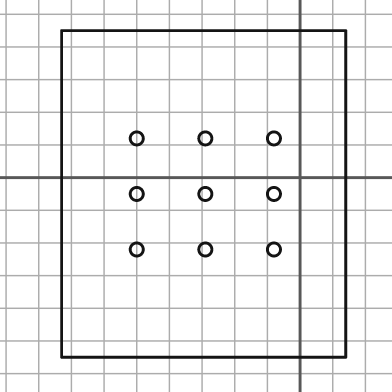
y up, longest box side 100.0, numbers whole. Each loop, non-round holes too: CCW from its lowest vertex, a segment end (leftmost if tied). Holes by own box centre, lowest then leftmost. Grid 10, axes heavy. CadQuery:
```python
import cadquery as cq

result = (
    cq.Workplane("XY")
    .moveTo(-73.0, -55.0)
    .lineTo(14.0, -55.0)
    .lineTo(14.0, 45.0)
    .lineTo(-73.0, 45.0)
    .close()
    .moveTo(-50.0, -22.0)
    .circle(2.0)
    .moveTo(-29.0, -22.0)
    .circle(2.0)
    .moveTo(-8.0, -22.0)
    .circle(2.0)
    .moveTo(-50.0, -5.0)
    .circle(2.0)
    .moveTo(-29.0, -5.0)
    .circle(2.0)
    .moveTo(-8.0, -5.0)
    .circle(2.0)
    .moveTo(-50.0, 12.0)
    .circle(2.0)
    .moveTo(-29.0, 12.0)
    .circle(2.0)
    .moveTo(-8.0, 12.0)
    .circle(2.0)
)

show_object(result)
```